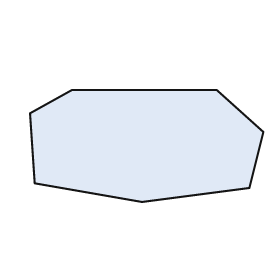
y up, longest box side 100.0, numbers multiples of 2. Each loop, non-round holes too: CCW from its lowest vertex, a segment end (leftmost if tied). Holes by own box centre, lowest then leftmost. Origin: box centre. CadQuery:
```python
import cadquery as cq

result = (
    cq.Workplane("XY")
    .moveTo(-2.0, -24.0)
    .lineTo(44.0, -18.0)
    .lineTo(50.0, 6.0)
    .lineTo(30.0, 24.0)
    .lineTo(-32.0, 24.0)
    .lineTo(-50.0, 14.0)
    .lineTo(-48.0, -16.0)
    .close()
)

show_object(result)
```